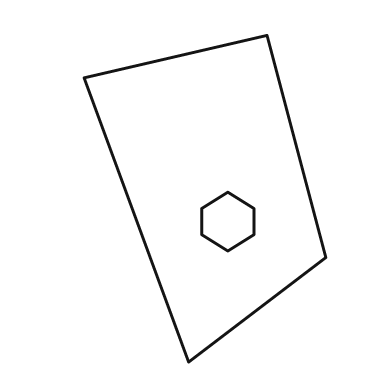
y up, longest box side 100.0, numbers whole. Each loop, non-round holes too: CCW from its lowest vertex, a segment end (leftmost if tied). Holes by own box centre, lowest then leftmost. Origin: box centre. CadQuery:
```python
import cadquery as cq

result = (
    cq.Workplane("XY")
    .moveTo(-5.0, -50.0)
    .lineTo(37.0, -18.0)
    .lineTo(19.0, 50.0)
    .lineTo(-37.0, 37.0)
    .close()
    .moveTo(7.0, -16.0)
    .lineTo(15.0, -11.0)
    .lineTo(15.0, -3.0)
    .lineTo(7.0, 2.0)
    .lineTo(-1.0, -3.0)
    .lineTo(-1.0, -11.0)
    .close()
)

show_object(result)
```